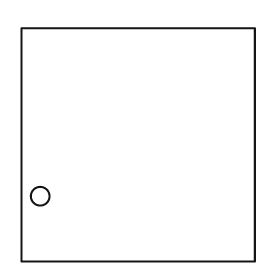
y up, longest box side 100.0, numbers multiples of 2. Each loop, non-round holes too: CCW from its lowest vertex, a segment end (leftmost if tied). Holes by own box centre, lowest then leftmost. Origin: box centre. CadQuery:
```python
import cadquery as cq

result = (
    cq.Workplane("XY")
    .moveTo(-50.0, -50.0)
    .lineTo(50.0, -50.0)
    .lineTo(50.0, 50.0)
    .lineTo(-50.0, 50.0)
    .close()
    .moveTo(-42.0, -22.0)
    .circle(4.0)
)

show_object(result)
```